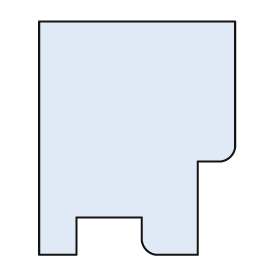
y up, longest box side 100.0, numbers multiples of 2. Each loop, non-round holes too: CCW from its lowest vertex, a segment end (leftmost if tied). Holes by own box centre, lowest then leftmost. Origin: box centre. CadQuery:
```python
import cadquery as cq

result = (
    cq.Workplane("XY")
    .moveTo(-42.0, -50.0)
    .lineTo(-26.0, -50.0)
    .lineTo(-26.0, -34.0)
    .lineTo(2.0, -34.0)
    .lineTo(2.0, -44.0)
    .threePointArc((4.0, -48.0), (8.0, -50.0))
    .lineTo(26.0, -50.0)
    .lineTo(26.0, -10.0)
    .lineTo(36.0, -10.0)
    .threePointArc((40.0, -8.0), (42.0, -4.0))
    .lineTo(42.0, 50.0)
    .lineTo(-42.0, 50.0)
    .close()
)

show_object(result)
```